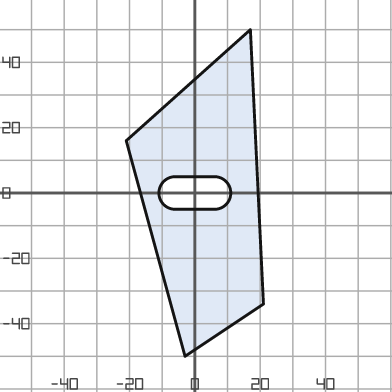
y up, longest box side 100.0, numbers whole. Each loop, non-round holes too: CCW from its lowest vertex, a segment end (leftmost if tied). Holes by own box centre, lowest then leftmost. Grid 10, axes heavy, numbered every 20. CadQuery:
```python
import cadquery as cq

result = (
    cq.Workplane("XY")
    .moveTo(-3.0, -50.0)
    .lineTo(21.0, -34.0)
    .lineTo(17.0, 50.0)
    .lineTo(-21.0, 16.0)
    .close()
    .moveTo(-6.0, -5.0)
    .lineTo(6.0, -5.0)
    .threePointArc((11.0, 0.0), (6.0, 5.0))
    .lineTo(-6.0, 5.0)
    .threePointArc((-11.0, 0.0), (-6.0, -5.0))
    .close()
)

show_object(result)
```